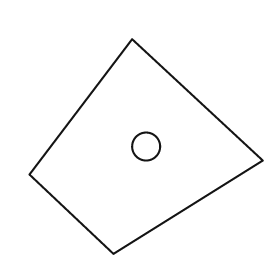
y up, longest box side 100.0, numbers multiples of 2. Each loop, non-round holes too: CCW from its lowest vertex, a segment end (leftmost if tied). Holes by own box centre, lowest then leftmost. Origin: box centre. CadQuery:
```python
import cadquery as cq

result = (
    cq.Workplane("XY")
    .moveTo(-14.0, -46.0)
    .lineTo(50.0, -6.0)
    .lineTo(-6.0, 46.0)
    .lineTo(-50.0, -12.0)
    .close()
    .moveTo(0.0, 0.0)
    .circle(6.0)
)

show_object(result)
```